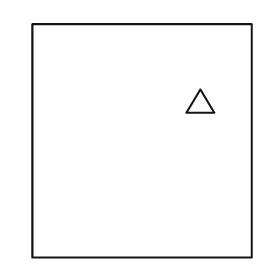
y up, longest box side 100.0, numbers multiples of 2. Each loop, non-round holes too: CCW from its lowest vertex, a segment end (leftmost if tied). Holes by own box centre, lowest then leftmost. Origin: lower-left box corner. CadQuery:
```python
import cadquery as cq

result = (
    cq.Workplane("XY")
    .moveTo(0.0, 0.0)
    .lineTo(94.0, 0.0)
    .lineTo(94.0, 100.0)
    .lineTo(0.0, 100.0)
    .close()
    .moveTo(66.0, 62.0)
    .lineTo(78.0, 62.0)
    .lineTo(72.0, 72.0)
    .close()
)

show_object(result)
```